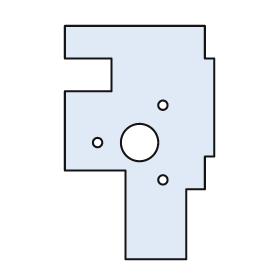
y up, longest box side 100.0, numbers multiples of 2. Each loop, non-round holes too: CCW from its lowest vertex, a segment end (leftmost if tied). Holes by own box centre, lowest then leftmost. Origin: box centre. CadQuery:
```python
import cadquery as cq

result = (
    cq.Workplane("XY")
    .moveTo(-6.0, -50.0)
    .lineTo(20.0, -50.0)
    .lineTo(20.0, -20.0)
    .lineTo(28.0, -20.0)
    .lineTo(28.0, -6.0)
    .lineTo(32.0, -6.0)
    .lineTo(32.0, 36.0)
    .lineTo(28.0, 36.0)
    .lineTo(28.0, 50.0)
    .lineTo(-32.0, 50.0)
    .lineTo(-32.0, 36.0)
    .lineTo(-12.0, 36.0)
    .lineTo(-12.0, 22.0)
    .lineTo(-32.0, 22.0)
    .lineTo(-32.0, -12.0)
    .lineTo(-6.0, -12.0)
    .close()
    .moveTo(10.0, -16.0)
    .circle(2.0)
    .moveTo(-18.0, 0.0)
    .circle(2.0)
    .moveTo(0.0, 0.0)
    .circle(8.0)
    .moveTo(10.0, 16.0)
    .circle(2.0)
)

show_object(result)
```